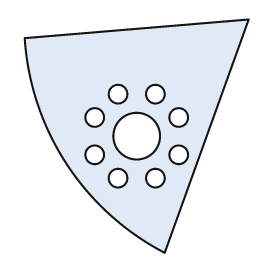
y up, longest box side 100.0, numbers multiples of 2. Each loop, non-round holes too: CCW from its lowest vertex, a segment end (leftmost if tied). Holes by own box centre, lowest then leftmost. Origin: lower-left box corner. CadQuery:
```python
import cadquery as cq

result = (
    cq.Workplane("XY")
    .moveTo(60.0, 0.0)
    .lineTo(96.0, 100.0)
    .lineTo(0.0, 92.0)
    .threePointArc((18.0, 38.0), (60.0, 0.0))
    .close()
    .moveTo(40.0, 32.0)
    .circle(4.0)
    .moveTo(56.0, 32.0)
    .circle(4.0)
    .moveTo(30.0, 42.0)
    .circle(4.0)
    .moveTo(66.0, 42.0)
    .circle(4.0)
    .moveTo(48.0, 50.0)
    .circle(10.0)
    .moveTo(30.0, 58.0)
    .circle(4.0)
    .moveTo(66.0, 58.0)
    .circle(4.0)
    .moveTo(40.0, 68.0)
    .circle(4.0)
    .moveTo(56.0, 68.0)
    .circle(4.0)
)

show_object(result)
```